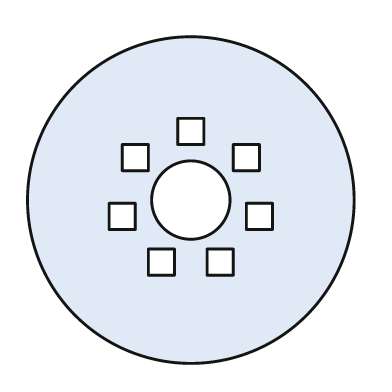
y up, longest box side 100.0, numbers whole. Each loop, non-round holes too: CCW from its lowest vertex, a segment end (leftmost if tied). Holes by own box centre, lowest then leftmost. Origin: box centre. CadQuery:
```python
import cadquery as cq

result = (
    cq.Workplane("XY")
    .moveTo(0.0, 0.0)
    .circle(50.0)
    .moveTo(-13.0, -23.0)
    .lineTo(-5.0, -23.0)
    .lineTo(-5.0, -15.0)
    .lineTo(-13.0, -15.0)
    .close()
    .moveTo(5.0, -23.0)
    .lineTo(13.0, -23.0)
    .lineTo(13.0, -15.0)
    .lineTo(5.0, -15.0)
    .close()
    .moveTo(-25.0, -9.0)
    .lineTo(-17.0, -9.0)
    .lineTo(-17.0, -1.0)
    .lineTo(-25.0, -1.0)
    .close()
    .moveTo(17.0, -9.0)
    .lineTo(25.0, -9.0)
    .lineTo(25.0, -1.0)
    .lineTo(17.0, -1.0)
    .close()
    .moveTo(0.0, 0.0)
    .circle(12.0)
    .moveTo(-21.0, 9.0)
    .lineTo(-13.0, 9.0)
    .lineTo(-13.0, 17.0)
    .lineTo(-21.0, 17.0)
    .close()
    .moveTo(13.0, 9.0)
    .lineTo(21.0, 9.0)
    .lineTo(21.0, 17.0)
    .lineTo(13.0, 17.0)
    .close()
    .moveTo(-4.0, 17.0)
    .lineTo(4.0, 17.0)
    .lineTo(4.0, 25.0)
    .lineTo(-4.0, 25.0)
    .close()
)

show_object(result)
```